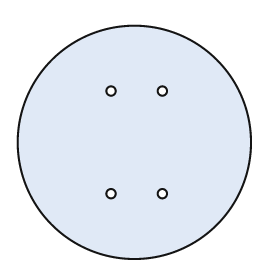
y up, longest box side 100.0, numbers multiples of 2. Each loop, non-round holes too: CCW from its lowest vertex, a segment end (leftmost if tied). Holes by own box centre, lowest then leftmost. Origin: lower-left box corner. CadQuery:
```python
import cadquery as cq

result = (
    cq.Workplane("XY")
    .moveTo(50.0, 50.0)
    .circle(50.0)
    .moveTo(40.0, 28.0)
    .circle(2.0)
    .moveTo(62.0, 28.0)
    .circle(2.0)
    .moveTo(40.0, 72.0)
    .circle(2.0)
    .moveTo(62.0, 72.0)
    .circle(2.0)
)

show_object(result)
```